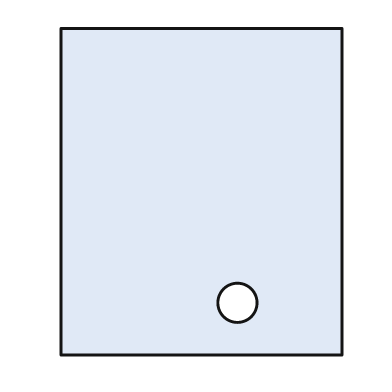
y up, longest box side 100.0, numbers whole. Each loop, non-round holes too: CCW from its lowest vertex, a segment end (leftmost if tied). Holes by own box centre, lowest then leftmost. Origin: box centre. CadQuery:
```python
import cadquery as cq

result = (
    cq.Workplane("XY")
    .moveTo(-43.0, -50.0)
    .lineTo(43.0, -50.0)
    .lineTo(43.0, 50.0)
    .lineTo(-43.0, 50.0)
    .close()
    .moveTo(11.0, -34.0)
    .circle(6.0)
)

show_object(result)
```